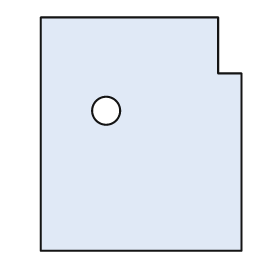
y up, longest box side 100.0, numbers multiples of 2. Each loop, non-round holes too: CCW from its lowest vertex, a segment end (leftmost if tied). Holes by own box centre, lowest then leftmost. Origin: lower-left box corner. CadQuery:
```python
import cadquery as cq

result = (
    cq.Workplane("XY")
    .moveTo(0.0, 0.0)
    .lineTo(86.0, 0.0)
    .lineTo(86.0, 76.0)
    .lineTo(76.0, 76.0)
    .lineTo(76.0, 100.0)
    .lineTo(0.0, 100.0)
    .close()
    .moveTo(28.0, 60.0)
    .circle(6.0)
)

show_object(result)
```